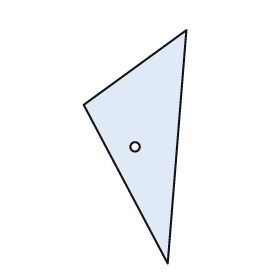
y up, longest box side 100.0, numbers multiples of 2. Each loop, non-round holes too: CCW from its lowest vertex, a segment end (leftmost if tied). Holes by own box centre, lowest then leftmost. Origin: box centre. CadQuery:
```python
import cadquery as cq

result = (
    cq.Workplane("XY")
    .moveTo(14.0, -50.0)
    .lineTo(22.0, 50.0)
    .lineTo(-22.0, 18.0)
    .close()
    .moveTo(0.0, 0.0)
    .circle(2.0)
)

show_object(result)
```